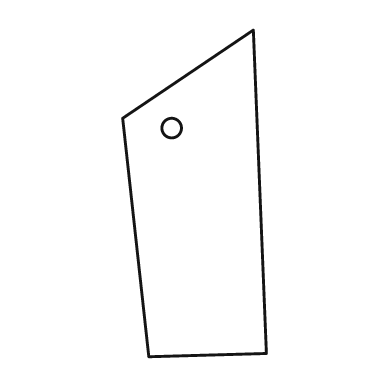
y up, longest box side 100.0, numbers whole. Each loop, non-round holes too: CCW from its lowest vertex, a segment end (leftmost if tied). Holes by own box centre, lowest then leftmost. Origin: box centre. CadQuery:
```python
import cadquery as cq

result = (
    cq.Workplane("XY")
    .moveTo(-14.0, -50.0)
    .lineTo(22.0, -49.0)
    .lineTo(18.0, 50.0)
    .lineTo(-22.0, 23.0)
    .close()
    .moveTo(-7.0, 20.0)
    .circle(3.0)
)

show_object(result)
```